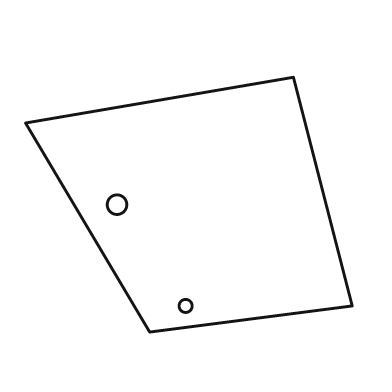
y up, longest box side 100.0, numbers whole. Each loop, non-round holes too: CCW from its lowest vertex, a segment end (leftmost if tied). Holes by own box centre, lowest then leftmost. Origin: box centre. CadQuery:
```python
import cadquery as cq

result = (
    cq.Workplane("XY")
    .moveTo(-12.0, -39.0)
    .lineTo(50.0, -31.0)
    .lineTo(32.0, 39.0)
    .lineTo(-50.0, 25.0)
    .close()
    .moveTo(-1.0, -31.0)
    .circle(2.0)
    .moveTo(-22.0, 0.0)
    .circle(3.0)
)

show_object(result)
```